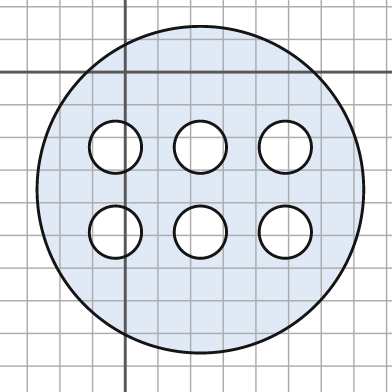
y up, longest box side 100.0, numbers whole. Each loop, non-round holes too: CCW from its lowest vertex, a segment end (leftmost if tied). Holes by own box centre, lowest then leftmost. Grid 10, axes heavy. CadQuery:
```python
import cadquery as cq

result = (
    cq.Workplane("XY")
    .moveTo(23.0, -36.0)
    .circle(50.0)
    .moveTo(-3.0, -49.0)
    .circle(8.0)
    .moveTo(23.0, -49.0)
    .circle(8.0)
    .moveTo(49.0, -49.0)
    .circle(8.0)
    .moveTo(-3.0, -23.0)
    .circle(8.0)
    .moveTo(23.0, -23.0)
    .circle(8.0)
    .moveTo(49.0, -23.0)
    .circle(8.0)
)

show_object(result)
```